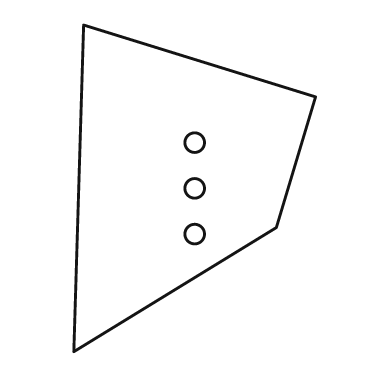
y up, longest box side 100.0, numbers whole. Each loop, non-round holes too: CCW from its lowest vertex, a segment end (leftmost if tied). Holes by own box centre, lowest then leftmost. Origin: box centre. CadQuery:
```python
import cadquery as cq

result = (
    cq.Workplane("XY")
    .moveTo(-37.0, -50.0)
    .lineTo(25.0, -12.0)
    .lineTo(37.0, 28.0)
    .lineTo(-34.0, 50.0)
    .close()
    .moveTo(0.0, -14.0)
    .circle(3.0)
    .moveTo(0.0, 0.0)
    .circle(3.0)
    .moveTo(0.0, 14.0)
    .circle(3.0)
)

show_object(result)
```